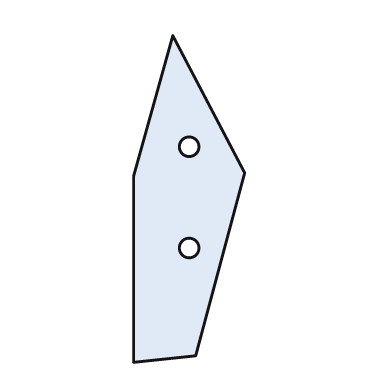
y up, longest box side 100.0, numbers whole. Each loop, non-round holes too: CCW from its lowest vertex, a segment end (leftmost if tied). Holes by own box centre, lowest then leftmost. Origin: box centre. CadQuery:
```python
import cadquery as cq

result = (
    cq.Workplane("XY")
    .moveTo(-17.0, -50.0)
    .lineTo(2.0, -48.0)
    .lineTo(17.0, 8.0)
    .lineTo(-5.0, 50.0)
    .lineTo(-17.0, 7.0)
    .close()
    .moveTo(0.0, -15.0)
    .circle(3.0)
    .moveTo(0.0, 16.0)
    .circle(3.0)
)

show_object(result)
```